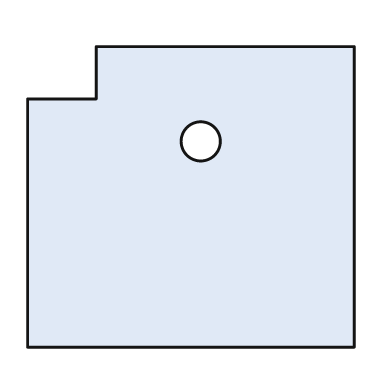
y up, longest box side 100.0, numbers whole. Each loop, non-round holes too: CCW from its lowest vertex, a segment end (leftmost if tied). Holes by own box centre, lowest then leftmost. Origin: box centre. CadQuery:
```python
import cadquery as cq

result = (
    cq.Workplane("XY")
    .moveTo(-50.0, -46.0)
    .lineTo(50.0, -46.0)
    .lineTo(50.0, 46.0)
    .lineTo(-29.0, 46.0)
    .lineTo(-29.0, 30.0)
    .lineTo(-50.0, 30.0)
    .close()
    .moveTo(3.0, 17.0)
    .circle(6.0)
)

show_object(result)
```